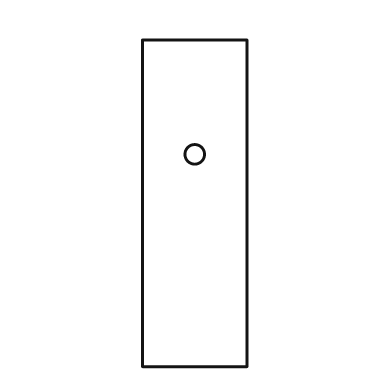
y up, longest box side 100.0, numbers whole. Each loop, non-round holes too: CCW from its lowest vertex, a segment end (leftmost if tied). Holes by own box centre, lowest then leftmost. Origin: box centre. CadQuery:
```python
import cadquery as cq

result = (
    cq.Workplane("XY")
    .moveTo(-16.0, -50.0)
    .lineTo(16.0, -50.0)
    .lineTo(16.0, 50.0)
    .lineTo(-16.0, 50.0)
    .close()
    .moveTo(0.0, 15.0)
    .circle(3.0)
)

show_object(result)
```